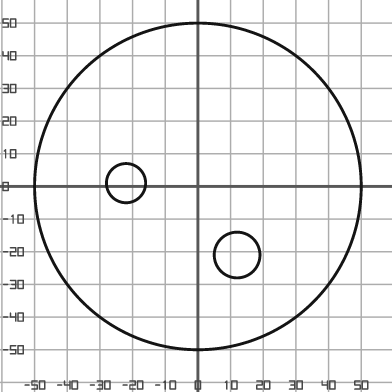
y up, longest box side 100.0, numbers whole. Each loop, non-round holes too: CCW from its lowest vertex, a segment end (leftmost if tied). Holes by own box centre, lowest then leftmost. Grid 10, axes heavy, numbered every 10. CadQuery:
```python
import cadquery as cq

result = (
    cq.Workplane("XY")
    .moveTo(0.0, 0.0)
    .circle(50.0)
    .moveTo(12.0, -21.0)
    .circle(7.0)
    .moveTo(-22.0, 1.0)
    .circle(6.0)
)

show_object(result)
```